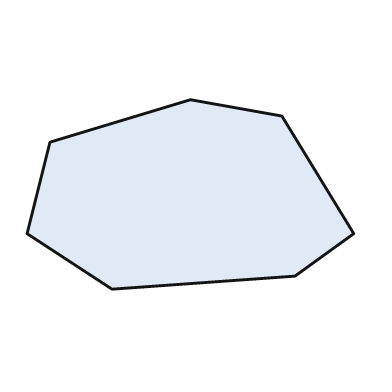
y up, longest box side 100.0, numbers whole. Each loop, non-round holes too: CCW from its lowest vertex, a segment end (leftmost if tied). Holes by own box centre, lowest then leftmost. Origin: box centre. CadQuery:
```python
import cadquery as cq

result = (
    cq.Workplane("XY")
    .moveTo(-24.0, -29.0)
    .lineTo(32.0, -25.0)
    .lineTo(50.0, -12.0)
    .lineTo(28.0, 24.0)
    .lineTo(0.0, 29.0)
    .lineTo(-43.0, 16.0)
    .lineTo(-50.0, -12.0)
    .close()
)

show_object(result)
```